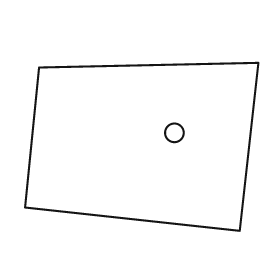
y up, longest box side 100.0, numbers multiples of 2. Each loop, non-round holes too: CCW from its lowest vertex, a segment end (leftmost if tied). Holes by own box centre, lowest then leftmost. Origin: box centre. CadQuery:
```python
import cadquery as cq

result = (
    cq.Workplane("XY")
    .moveTo(42.0, -36.0)
    .lineTo(50.0, 36.0)
    .lineTo(-44.0, 34.0)
    .lineTo(-50.0, -26.0)
    .close()
    .moveTo(14.0, 6.0)
    .circle(4.0)
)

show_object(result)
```